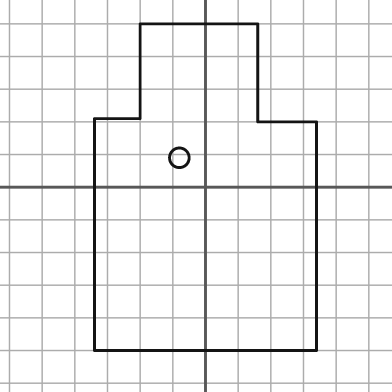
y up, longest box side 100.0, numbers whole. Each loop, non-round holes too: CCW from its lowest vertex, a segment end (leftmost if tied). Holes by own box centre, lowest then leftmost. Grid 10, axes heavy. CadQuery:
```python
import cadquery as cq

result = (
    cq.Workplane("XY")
    .moveTo(-34.0, -50.0)
    .lineTo(34.0, -50.0)
    .lineTo(34.0, 20.0)
    .lineTo(16.0, 20.0)
    .lineTo(16.0, 50.0)
    .lineTo(-20.0, 50.0)
    .lineTo(-20.0, 21.0)
    .lineTo(-34.0, 21.0)
    .close()
    .moveTo(-8.0, 9.0)
    .circle(3.0)
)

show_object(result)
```